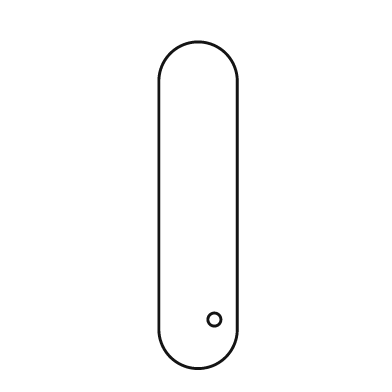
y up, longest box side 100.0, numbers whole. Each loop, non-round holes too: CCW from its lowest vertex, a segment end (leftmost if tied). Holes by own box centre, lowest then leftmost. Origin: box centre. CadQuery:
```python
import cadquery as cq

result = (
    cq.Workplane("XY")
    .moveTo(-12.0, -38.0)
    .threePointArc((0.0, -50.0), (12.0, -38.0))
    .lineTo(12.0, 38.0)
    .threePointArc((0.0, 50.0), (-12.0, 38.0))
    .close()
    .moveTo(5.0, -35.0)
    .circle(2.0)
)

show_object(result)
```